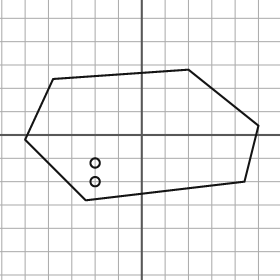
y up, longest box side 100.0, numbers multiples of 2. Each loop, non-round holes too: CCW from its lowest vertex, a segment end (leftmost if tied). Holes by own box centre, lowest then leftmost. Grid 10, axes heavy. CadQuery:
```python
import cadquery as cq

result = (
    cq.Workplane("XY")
    .moveTo(-24.0, -28.0)
    .lineTo(44.0, -20.0)
    .lineTo(50.0, 4.0)
    .lineTo(20.0, 28.0)
    .lineTo(-38.0, 24.0)
    .lineTo(-50.0, -2.0)
    .close()
    .moveTo(-20.0, -20.0)
    .circle(2.0)
    .moveTo(-20.0, -12.0)
    .circle(2.0)
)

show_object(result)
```